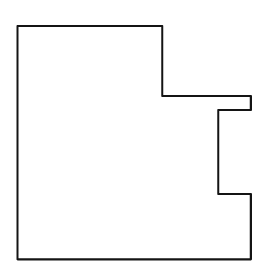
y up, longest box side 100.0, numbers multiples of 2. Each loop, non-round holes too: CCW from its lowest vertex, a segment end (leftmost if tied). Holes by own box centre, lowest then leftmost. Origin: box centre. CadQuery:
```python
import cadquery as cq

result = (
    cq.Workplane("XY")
    .moveTo(-50.0, -50.0)
    .lineTo(50.0, -50.0)
    .lineTo(50.0, -22.0)
    .lineTo(36.0, -22.0)
    .lineTo(36.0, 14.0)
    .lineTo(50.0, 14.0)
    .lineTo(50.0, 20.0)
    .lineTo(12.0, 20.0)
    .lineTo(12.0, 50.0)
    .lineTo(-50.0, 50.0)
    .close()
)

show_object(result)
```